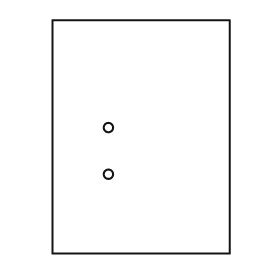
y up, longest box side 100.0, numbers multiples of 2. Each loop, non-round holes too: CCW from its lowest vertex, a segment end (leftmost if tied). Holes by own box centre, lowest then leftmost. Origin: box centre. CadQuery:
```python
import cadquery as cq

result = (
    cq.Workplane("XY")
    .moveTo(-38.0, -50.0)
    .lineTo(38.0, -50.0)
    .lineTo(38.0, 50.0)
    .lineTo(-38.0, 50.0)
    .close()
    .moveTo(-14.0, -16.0)
    .circle(2.0)
    .moveTo(-14.0, 4.0)
    .circle(2.0)
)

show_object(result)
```